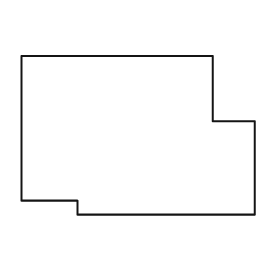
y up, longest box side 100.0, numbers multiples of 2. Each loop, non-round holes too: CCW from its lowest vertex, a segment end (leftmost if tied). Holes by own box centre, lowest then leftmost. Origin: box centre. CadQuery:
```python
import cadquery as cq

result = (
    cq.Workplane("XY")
    .moveTo(-26.0, -34.0)
    .lineTo(50.0, -34.0)
    .lineTo(50.0, 6.0)
    .lineTo(32.0, 6.0)
    .lineTo(32.0, 34.0)
    .lineTo(-50.0, 34.0)
    .lineTo(-50.0, -28.0)
    .lineTo(-26.0, -28.0)
    .close()
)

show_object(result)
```